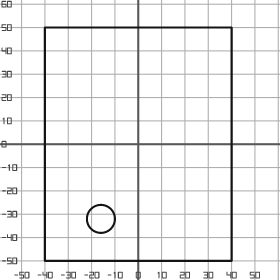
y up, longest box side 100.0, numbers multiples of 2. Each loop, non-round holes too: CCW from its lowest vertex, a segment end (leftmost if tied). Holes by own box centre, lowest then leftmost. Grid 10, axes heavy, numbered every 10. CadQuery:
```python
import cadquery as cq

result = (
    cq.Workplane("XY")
    .moveTo(-40.0, -50.0)
    .lineTo(40.0, -50.0)
    .lineTo(40.0, 50.0)
    .lineTo(-40.0, 50.0)
    .close()
    .moveTo(-16.0, -32.0)
    .circle(6.0)
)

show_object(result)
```